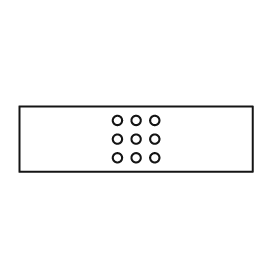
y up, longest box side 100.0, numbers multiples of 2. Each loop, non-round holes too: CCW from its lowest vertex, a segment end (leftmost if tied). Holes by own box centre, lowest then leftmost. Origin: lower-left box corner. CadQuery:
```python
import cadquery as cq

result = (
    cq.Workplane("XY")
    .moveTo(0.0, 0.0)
    .lineTo(100.0, 0.0)
    .lineTo(100.0, 28.0)
    .lineTo(0.0, 28.0)
    .close()
    .moveTo(42.0, 6.0)
    .circle(2.0)
    .moveTo(50.0, 6.0)
    .circle(2.0)
    .moveTo(58.0, 6.0)
    .circle(2.0)
    .moveTo(42.0, 14.0)
    .circle(2.0)
    .moveTo(50.0, 14.0)
    .circle(2.0)
    .moveTo(58.0, 14.0)
    .circle(2.0)
    .moveTo(42.0, 22.0)
    .circle(2.0)
    .moveTo(50.0, 22.0)
    .circle(2.0)
    .moveTo(58.0, 22.0)
    .circle(2.0)
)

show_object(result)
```